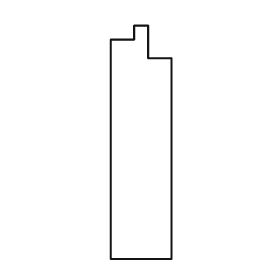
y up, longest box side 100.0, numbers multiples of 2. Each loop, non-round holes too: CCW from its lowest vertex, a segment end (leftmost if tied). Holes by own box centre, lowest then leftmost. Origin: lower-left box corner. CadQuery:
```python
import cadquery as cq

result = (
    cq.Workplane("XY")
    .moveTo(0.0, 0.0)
    .lineTo(26.0, 0.0)
    .lineTo(26.0, 86.0)
    .lineTo(16.0, 86.0)
    .lineTo(16.0, 100.0)
    .lineTo(10.0, 100.0)
    .lineTo(10.0, 94.0)
    .lineTo(0.0, 94.0)
    .close()
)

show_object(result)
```